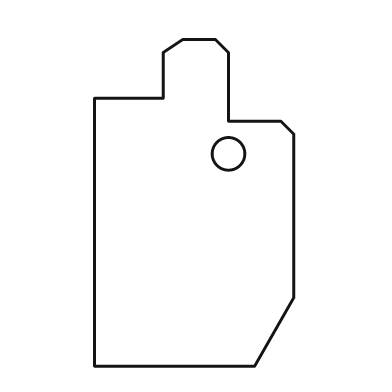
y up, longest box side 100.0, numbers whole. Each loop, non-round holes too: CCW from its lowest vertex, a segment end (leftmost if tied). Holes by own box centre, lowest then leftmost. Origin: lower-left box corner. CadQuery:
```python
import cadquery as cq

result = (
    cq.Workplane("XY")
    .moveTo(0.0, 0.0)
    .lineTo(49.0, 0.0)
    .lineTo(61.0, 21.0)
    .lineTo(61.0, 71.0)
    .lineTo(57.0, 75.0)
    .lineTo(41.0, 75.0)
    .lineTo(41.0, 96.0)
    .lineTo(37.0, 100.0)
    .lineTo(27.0, 100.0)
    .lineTo(21.0, 96.0)
    .lineTo(21.0, 82.0)
    .lineTo(0.0, 82.0)
    .close()
    .moveTo(41.0, 65.0)
    .circle(5.0)
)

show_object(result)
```